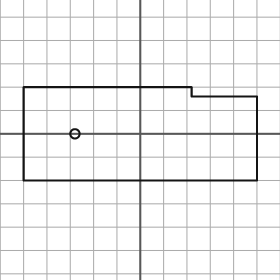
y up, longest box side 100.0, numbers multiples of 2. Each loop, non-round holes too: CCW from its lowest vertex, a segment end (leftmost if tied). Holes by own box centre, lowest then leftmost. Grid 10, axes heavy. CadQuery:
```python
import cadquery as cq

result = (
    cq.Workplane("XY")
    .moveTo(-50.0, -20.0)
    .lineTo(50.0, -20.0)
    .lineTo(50.0, 16.0)
    .lineTo(22.0, 16.0)
    .lineTo(22.0, 20.0)
    .lineTo(-50.0, 20.0)
    .close()
    .moveTo(-28.0, 0.0)
    .circle(2.0)
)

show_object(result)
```